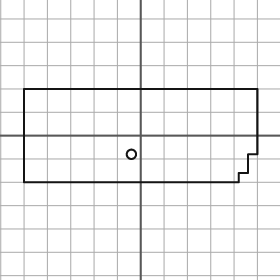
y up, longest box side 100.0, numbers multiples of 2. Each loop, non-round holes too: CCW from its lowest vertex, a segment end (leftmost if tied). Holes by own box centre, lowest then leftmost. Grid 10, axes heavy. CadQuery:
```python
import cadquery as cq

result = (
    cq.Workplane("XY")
    .moveTo(-50.0, -20.0)
    .lineTo(42.0, -20.0)
    .lineTo(42.0, -16.0)
    .lineTo(46.0, -16.0)
    .lineTo(46.0, -8.0)
    .lineTo(50.0, -8.0)
    .lineTo(50.0, 20.0)
    .lineTo(-50.0, 20.0)
    .close()
    .moveTo(-4.0, -8.0)
    .circle(2.0)
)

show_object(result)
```